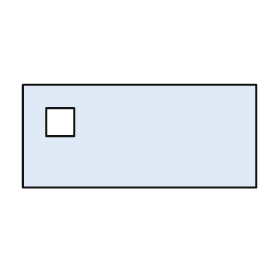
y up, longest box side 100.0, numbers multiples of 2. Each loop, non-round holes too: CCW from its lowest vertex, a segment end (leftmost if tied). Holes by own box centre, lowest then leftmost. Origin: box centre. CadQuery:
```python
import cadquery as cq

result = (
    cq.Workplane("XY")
    .moveTo(-50.0, -22.0)
    .lineTo(50.0, -22.0)
    .lineTo(50.0, 22.0)
    .lineTo(-50.0, 22.0)
    .close()
    .moveTo(-40.0, 0.0)
    .lineTo(-28.0, 0.0)
    .lineTo(-28.0, 12.0)
    .lineTo(-40.0, 12.0)
    .close()
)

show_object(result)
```